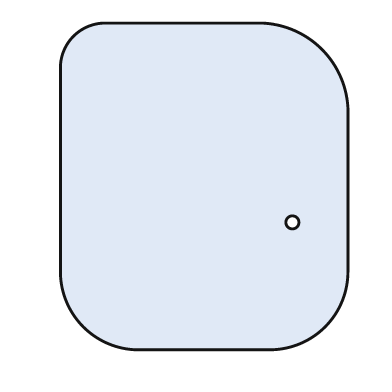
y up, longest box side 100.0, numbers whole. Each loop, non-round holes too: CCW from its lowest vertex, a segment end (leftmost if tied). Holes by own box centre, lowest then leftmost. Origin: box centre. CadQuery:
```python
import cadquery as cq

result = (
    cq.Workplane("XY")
    .moveTo(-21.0, -50.0)
    .lineTo(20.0, -50.0)
    .threePointArc((37.0, -43.0), (44.0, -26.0))
    .lineTo(44.0, 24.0)
    .threePointArc((36.0, 42.0), (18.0, 50.0))
    .lineTo(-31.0, 50.0)
    .threePointArc((-40.0, 46.0), (-44.0, 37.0))
    .lineTo(-44.0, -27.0)
    .threePointArc((-37.0, -43.0), (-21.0, -50.0))
    .close()
    .moveTo(27.0, -11.0)
    .circle(2.0)
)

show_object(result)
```